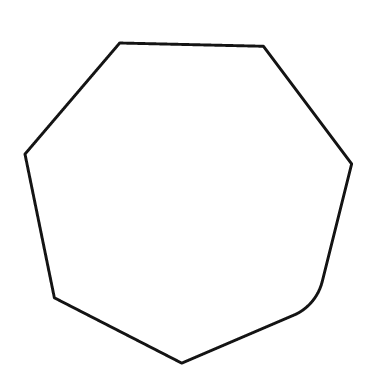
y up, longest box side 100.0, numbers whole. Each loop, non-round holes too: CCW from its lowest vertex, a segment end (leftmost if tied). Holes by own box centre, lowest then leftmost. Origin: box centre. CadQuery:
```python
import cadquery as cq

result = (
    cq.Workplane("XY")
    .moveTo(-2.0, -49.0)
    .lineTo(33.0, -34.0)
    .threePointArc((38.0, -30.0), (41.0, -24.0))
    .lineTo(50.0, 12.0)
    .lineTo(23.0, 48.0)
    .lineTo(-21.0, 49.0)
    .lineTo(-50.0, 15.0)
    .lineTo(-41.0, -29.0)
    .close()
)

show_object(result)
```